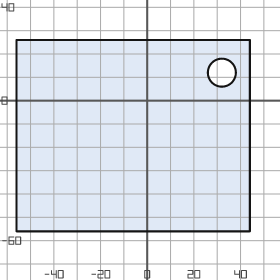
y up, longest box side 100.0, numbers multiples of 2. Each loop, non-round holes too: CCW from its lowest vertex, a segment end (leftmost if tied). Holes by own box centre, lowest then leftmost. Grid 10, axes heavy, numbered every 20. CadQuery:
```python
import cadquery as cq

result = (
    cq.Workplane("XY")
    .moveTo(-56.0, -56.0)
    .lineTo(44.0, -56.0)
    .lineTo(44.0, 26.0)
    .lineTo(-56.0, 26.0)
    .close()
    .moveTo(32.0, 12.0)
    .circle(6.0)
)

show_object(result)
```